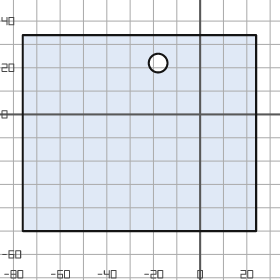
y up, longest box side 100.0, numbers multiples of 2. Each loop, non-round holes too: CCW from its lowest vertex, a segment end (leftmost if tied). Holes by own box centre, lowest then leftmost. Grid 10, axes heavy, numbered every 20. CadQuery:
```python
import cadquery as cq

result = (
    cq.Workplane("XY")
    .moveTo(-76.0, -50.0)
    .lineTo(24.0, -50.0)
    .lineTo(24.0, 34.0)
    .lineTo(-76.0, 34.0)
    .close()
    .moveTo(-18.0, 22.0)
    .circle(4.0)
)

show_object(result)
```